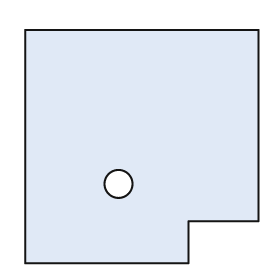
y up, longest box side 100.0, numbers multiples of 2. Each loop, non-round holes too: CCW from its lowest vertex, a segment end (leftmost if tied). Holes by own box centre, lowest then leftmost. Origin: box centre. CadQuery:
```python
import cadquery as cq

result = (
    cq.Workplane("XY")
    .moveTo(-50.0, -50.0)
    .lineTo(20.0, -50.0)
    .lineTo(20.0, -32.0)
    .lineTo(50.0, -32.0)
    .lineTo(50.0, 50.0)
    .lineTo(-50.0, 50.0)
    .close()
    .moveTo(-10.0, -16.0)
    .circle(6.0)
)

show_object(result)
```